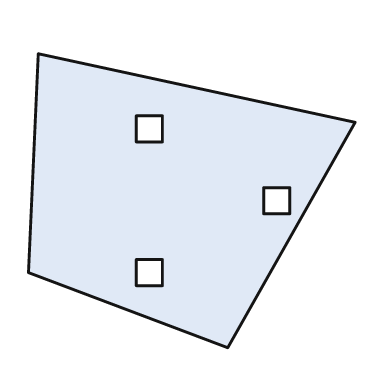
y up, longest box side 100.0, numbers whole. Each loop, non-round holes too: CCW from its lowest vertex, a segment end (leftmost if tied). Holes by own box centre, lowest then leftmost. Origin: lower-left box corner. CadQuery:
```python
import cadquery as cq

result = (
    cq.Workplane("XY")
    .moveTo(61.0, 0.0)
    .lineTo(100.0, 69.0)
    .lineTo(3.0, 90.0)
    .lineTo(0.0, 23.0)
    .close()
    .moveTo(33.0, 19.0)
    .lineTo(41.0, 19.0)
    .lineTo(41.0, 27.0)
    .lineTo(33.0, 27.0)
    .close()
    .moveTo(72.0, 41.0)
    .lineTo(80.0, 41.0)
    .lineTo(80.0, 49.0)
    .lineTo(72.0, 49.0)
    .close()
    .moveTo(33.0, 63.0)
    .lineTo(41.0, 63.0)
    .lineTo(41.0, 71.0)
    .lineTo(33.0, 71.0)
    .close()
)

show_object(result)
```